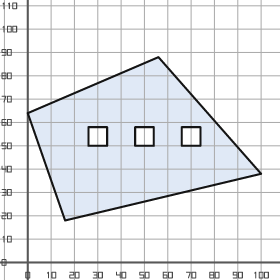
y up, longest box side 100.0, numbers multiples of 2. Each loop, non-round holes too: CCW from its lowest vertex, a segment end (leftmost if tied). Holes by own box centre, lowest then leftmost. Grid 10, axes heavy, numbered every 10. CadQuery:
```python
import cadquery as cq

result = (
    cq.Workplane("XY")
    .moveTo(16.0, 18.0)
    .lineTo(100.0, 38.0)
    .lineTo(56.0, 88.0)
    .lineTo(0.0, 64.0)
    .close()
    .moveTo(26.0, 50.0)
    .lineTo(34.0, 50.0)
    .lineTo(34.0, 58.0)
    .lineTo(26.0, 58.0)
    .close()
    .moveTo(46.0, 50.0)
    .lineTo(54.0, 50.0)
    .lineTo(54.0, 58.0)
    .lineTo(46.0, 58.0)
    .close()
    .moveTo(66.0, 50.0)
    .lineTo(74.0, 50.0)
    .lineTo(74.0, 58.0)
    .lineTo(66.0, 58.0)
    .close()
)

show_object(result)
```